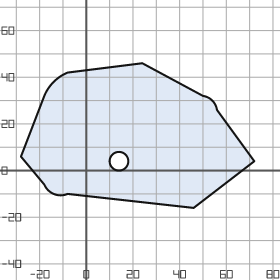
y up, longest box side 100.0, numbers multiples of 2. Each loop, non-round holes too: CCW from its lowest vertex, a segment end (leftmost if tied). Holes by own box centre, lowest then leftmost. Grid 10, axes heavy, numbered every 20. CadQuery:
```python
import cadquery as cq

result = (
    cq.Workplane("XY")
    .moveTo(46.0, -16.0)
    .lineTo(72.0, 4.0)
    .lineTo(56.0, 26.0)
    .threePointArc((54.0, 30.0), (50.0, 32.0))
    .lineTo(24.0, 46.0)
    .lineTo(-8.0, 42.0)
    .threePointArc((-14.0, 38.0), (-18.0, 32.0))
    .lineTo(-28.0, 6.0)
    .lineTo(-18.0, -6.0)
    .threePointArc((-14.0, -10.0), (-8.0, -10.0))
    .close()
    .moveTo(14.0, 4.0)
    .circle(4.0)
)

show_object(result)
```